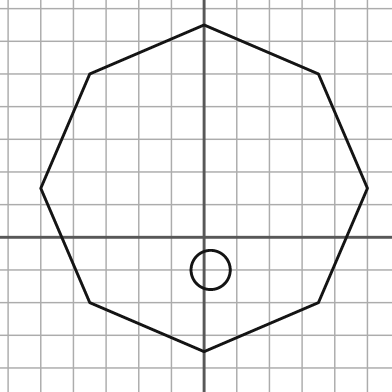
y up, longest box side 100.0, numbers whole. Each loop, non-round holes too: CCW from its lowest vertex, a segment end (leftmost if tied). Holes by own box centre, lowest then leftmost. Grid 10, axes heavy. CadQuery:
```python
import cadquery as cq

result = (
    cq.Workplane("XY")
    .moveTo(0.0, -35.0)
    .lineTo(35.0, -20.0)
    .lineTo(50.0, 15.0)
    .lineTo(35.0, 50.0)
    .lineTo(0.0, 65.0)
    .lineTo(-35.0, 50.0)
    .lineTo(-50.0, 15.0)
    .lineTo(-35.0, -20.0)
    .close()
    .moveTo(2.0, -10.0)
    .circle(6.0)
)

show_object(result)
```